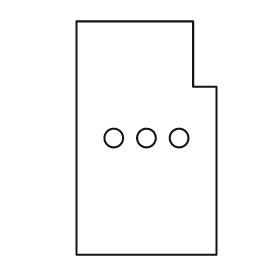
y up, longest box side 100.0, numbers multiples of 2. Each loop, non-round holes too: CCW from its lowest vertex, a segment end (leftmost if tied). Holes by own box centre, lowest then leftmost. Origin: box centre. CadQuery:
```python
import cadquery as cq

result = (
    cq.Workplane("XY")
    .moveTo(-30.0, -50.0)
    .lineTo(30.0, -50.0)
    .lineTo(30.0, 22.0)
    .lineTo(20.0, 22.0)
    .lineTo(20.0, 50.0)
    .lineTo(-30.0, 50.0)
    .close()
    .moveTo(-14.0, 0.0)
    .circle(4.0)
    .moveTo(0.0, 0.0)
    .circle(4.0)
    .moveTo(14.0, 0.0)
    .circle(4.0)
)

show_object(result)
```